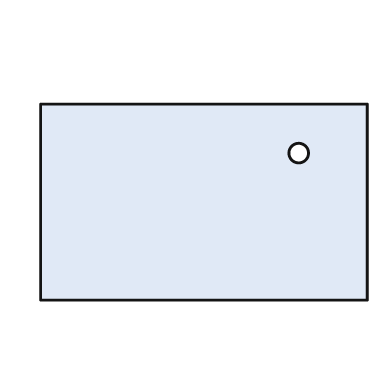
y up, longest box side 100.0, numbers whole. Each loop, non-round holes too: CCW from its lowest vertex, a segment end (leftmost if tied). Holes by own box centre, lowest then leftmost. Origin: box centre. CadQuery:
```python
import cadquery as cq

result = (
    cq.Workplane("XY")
    .moveTo(-50.0, -30.0)
    .lineTo(50.0, -30.0)
    .lineTo(50.0, 30.0)
    .lineTo(-50.0, 30.0)
    .close()
    .moveTo(29.0, 15.0)
    .circle(3.0)
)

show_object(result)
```